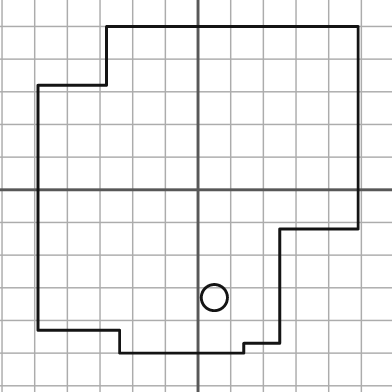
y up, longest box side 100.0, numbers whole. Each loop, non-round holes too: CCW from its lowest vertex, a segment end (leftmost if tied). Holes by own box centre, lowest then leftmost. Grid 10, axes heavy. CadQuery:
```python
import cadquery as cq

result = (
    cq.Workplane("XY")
    .moveTo(-24.0, -50.0)
    .lineTo(14.0, -50.0)
    .lineTo(14.0, -47.0)
    .lineTo(25.0, -47.0)
    .lineTo(25.0, -12.0)
    .lineTo(49.0, -12.0)
    .lineTo(49.0, 50.0)
    .lineTo(-28.0, 50.0)
    .lineTo(-28.0, 32.0)
    .lineTo(-49.0, 32.0)
    .lineTo(-49.0, -43.0)
    .lineTo(-24.0, -43.0)
    .close()
    .moveTo(5.0, -33.0)
    .circle(4.0)
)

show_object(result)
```